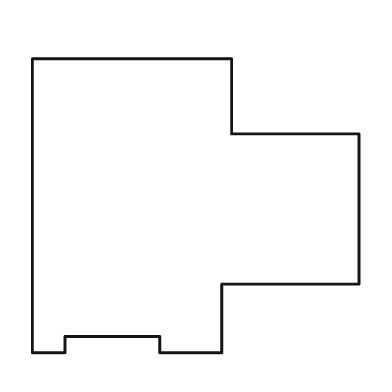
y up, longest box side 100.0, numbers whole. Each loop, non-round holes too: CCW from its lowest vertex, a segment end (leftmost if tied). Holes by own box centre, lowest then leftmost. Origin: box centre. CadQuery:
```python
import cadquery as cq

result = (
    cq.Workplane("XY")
    .moveTo(-50.0, -45.0)
    .lineTo(-40.0, -45.0)
    .lineTo(-40.0, -40.0)
    .lineTo(-11.0, -40.0)
    .lineTo(-11.0, -45.0)
    .lineTo(8.0, -45.0)
    .lineTo(8.0, -24.0)
    .lineTo(50.0, -24.0)
    .lineTo(50.0, 22.0)
    .lineTo(11.0, 22.0)
    .lineTo(11.0, 45.0)
    .lineTo(-50.0, 45.0)
    .close()
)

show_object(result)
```